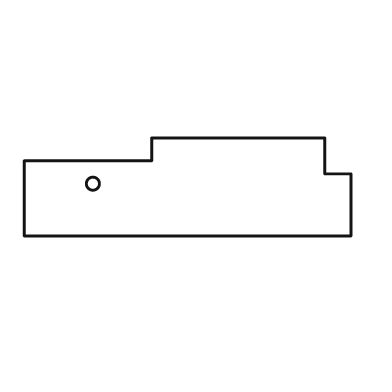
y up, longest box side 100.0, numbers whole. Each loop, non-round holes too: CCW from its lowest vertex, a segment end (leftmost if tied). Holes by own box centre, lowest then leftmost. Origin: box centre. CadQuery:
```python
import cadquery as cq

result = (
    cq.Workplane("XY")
    .moveTo(-50.0, -15.0)
    .lineTo(50.0, -15.0)
    .lineTo(50.0, 4.0)
    .lineTo(42.0, 4.0)
    .lineTo(42.0, 15.0)
    .lineTo(-11.0, 15.0)
    .lineTo(-11.0, 8.0)
    .lineTo(-50.0, 8.0)
    .close()
    .moveTo(-29.0, 1.0)
    .circle(2.0)
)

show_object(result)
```